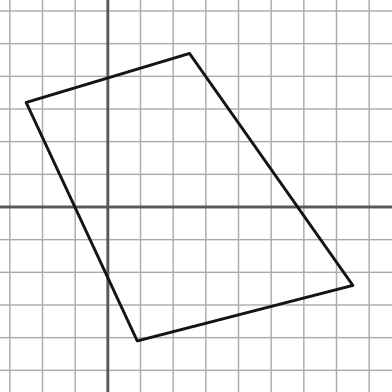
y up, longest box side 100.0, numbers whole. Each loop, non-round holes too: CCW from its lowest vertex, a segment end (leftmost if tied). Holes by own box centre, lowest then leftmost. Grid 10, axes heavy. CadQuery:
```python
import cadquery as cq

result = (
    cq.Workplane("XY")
    .moveTo(9.0, -41.0)
    .lineTo(75.0, -24.0)
    .lineTo(25.0, 47.0)
    .lineTo(-25.0, 32.0)
    .close()
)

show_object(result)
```